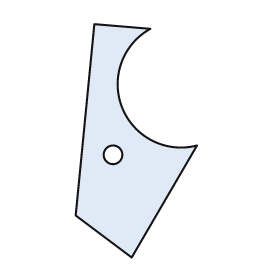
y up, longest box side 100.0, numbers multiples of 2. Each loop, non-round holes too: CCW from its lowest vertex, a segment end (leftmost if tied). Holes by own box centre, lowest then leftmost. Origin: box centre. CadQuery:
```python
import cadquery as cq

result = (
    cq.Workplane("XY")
    .moveTo(-2.0, -50.0)
    .lineTo(26.0, -2.0)
    .threePointArc((-6.0, 14.0), (6.0, 48.0))
    .lineTo(-18.0, 50.0)
    .lineTo(-26.0, -32.0)
    .close()
    .moveTo(-10.0, -6.0)
    .circle(4.0)
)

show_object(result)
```